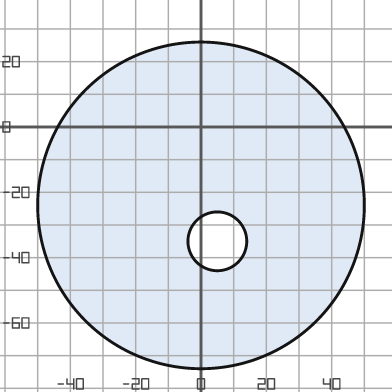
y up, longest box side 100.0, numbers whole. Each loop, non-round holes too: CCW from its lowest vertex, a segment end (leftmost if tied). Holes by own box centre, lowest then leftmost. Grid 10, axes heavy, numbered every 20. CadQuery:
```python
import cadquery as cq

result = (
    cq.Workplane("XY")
    .moveTo(0.0, -24.0)
    .circle(50.0)
    .moveTo(5.0, -35.0)
    .circle(9.0)
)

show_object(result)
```